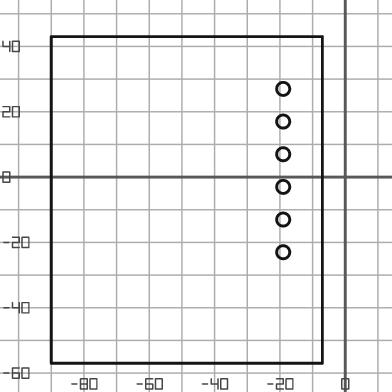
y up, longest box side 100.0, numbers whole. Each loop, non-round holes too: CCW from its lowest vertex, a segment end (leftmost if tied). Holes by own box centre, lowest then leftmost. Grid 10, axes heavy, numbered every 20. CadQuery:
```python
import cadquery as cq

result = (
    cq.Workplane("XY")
    .moveTo(-90.0, -57.0)
    .lineTo(-7.0, -57.0)
    .lineTo(-7.0, 43.0)
    .lineTo(-90.0, 43.0)
    .close()
    .moveTo(-19.0, -23.0)
    .circle(2.0)
    .moveTo(-19.0, -13.0)
    .circle(2.0)
    .moveTo(-19.0, -3.0)
    .circle(2.0)
    .moveTo(-19.0, 7.0)
    .circle(2.0)
    .moveTo(-19.0, 17.0)
    .circle(2.0)
    .moveTo(-19.0, 27.0)
    .circle(2.0)
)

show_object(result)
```